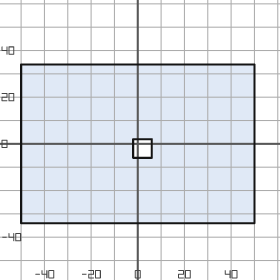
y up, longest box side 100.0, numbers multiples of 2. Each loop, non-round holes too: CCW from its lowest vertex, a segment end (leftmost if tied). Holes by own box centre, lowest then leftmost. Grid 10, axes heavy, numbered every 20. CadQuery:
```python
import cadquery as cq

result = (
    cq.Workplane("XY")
    .moveTo(-50.0, -34.0)
    .lineTo(50.0, -34.0)
    .lineTo(50.0, 34.0)
    .lineTo(-50.0, 34.0)
    .close()
    .moveTo(-2.0, -6.0)
    .lineTo(6.0, -6.0)
    .lineTo(6.0, 2.0)
    .lineTo(-2.0, 2.0)
    .close()
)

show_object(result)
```